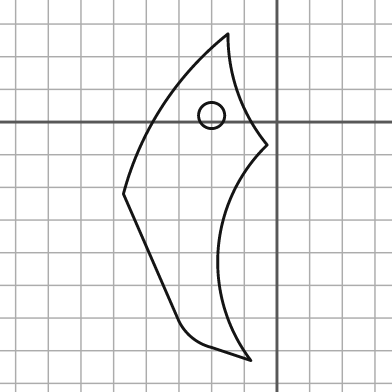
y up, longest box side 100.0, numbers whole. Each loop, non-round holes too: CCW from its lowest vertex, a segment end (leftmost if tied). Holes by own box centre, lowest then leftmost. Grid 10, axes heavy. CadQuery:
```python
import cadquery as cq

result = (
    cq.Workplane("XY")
    .moveTo(-8.0, -73.0)
    .threePointArc((-18.0, -39.0), (-3.0, -7.0))
    .threePointArc((-12.0, 9.0), (-15.0, 27.0))
    .threePointArc((-35.0, 5.0), (-47.0, -22.0))
    .lineTo(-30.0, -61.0)
    .threePointArc((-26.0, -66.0), (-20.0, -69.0))
    .close()
    .moveTo(-20.0, 2.0)
    .circle(4.0)
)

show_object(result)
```